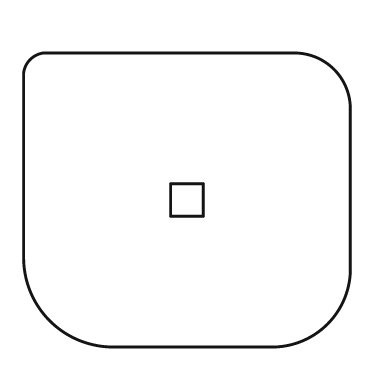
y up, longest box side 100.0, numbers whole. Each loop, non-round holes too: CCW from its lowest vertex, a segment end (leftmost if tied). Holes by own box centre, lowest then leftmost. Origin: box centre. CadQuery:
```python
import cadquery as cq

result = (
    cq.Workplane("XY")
    .moveTo(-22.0, -45.0)
    .lineTo(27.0, -45.0)
    .threePointArc((43.0, -38.0), (50.0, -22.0))
    .lineTo(50.0, 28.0)
    .threePointArc((45.0, 40.0), (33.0, 45.0))
    .lineTo(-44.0, 45.0)
    .threePointArc((-48.0, 43.0), (-50.0, 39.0))
    .lineTo(-50.0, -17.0)
    .threePointArc((-42.0, -37.0), (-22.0, -45.0))
    .close()
    .moveTo(-5.0, -5.0)
    .lineTo(5.0, -5.0)
    .lineTo(5.0, 5.0)
    .lineTo(-5.0, 5.0)
    .close()
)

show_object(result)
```